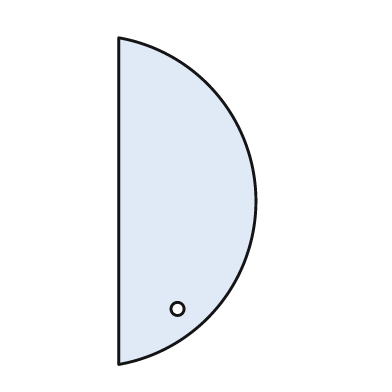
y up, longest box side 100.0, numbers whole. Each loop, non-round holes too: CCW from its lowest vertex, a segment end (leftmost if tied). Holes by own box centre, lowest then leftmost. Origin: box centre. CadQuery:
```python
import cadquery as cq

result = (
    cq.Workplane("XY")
    .moveTo(-21.0, -50.0)
    .threePointArc((21.0, 0.0), (-21.0, 50.0))
    .close()
    .moveTo(-3.0, -33.0)
    .circle(2.0)
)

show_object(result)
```